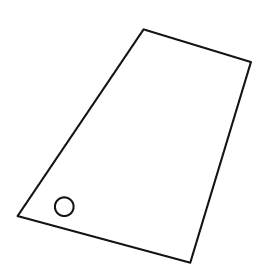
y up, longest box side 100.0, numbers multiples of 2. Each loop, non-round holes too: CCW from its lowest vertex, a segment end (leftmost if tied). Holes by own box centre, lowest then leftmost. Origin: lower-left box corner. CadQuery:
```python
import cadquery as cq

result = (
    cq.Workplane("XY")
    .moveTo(74.0, 0.0)
    .lineTo(100.0, 86.0)
    .lineTo(54.0, 100.0)
    .lineTo(0.0, 20.0)
    .close()
    .moveTo(20.0, 24.0)
    .circle(4.0)
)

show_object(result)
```